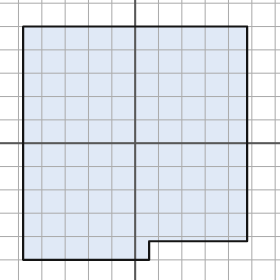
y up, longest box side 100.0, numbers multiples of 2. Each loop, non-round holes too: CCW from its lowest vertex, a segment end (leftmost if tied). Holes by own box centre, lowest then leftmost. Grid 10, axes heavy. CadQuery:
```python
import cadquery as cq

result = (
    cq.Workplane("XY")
    .moveTo(-48.0, -50.0)
    .lineTo(6.0, -50.0)
    .lineTo(6.0, -42.0)
    .lineTo(48.0, -42.0)
    .lineTo(48.0, 50.0)
    .lineTo(-48.0, 50.0)
    .close()
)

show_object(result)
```